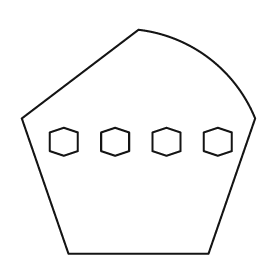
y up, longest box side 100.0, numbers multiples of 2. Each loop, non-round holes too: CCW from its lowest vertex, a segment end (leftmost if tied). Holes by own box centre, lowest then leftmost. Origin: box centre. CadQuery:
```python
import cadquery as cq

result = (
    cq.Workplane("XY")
    .moveTo(-30.0, -48.0)
    .lineTo(30.0, -48.0)
    .lineTo(50.0, 10.0)
    .threePointArc((30.0, 36.0), (0.0, 48.0))
    .lineTo(-50.0, 10.0)
    .close()
    .moveTo(-32.0, -6.0)
    .lineTo(-26.0, -4.0)
    .lineTo(-26.0, 4.0)
    .lineTo(-32.0, 6.0)
    .lineTo(-38.0, 4.0)
    .lineTo(-38.0, -4.0)
    .close()
    .moveTo(-10.0, -6.0)
    .lineTo(-4.0, -4.0)
    .lineTo(-4.0, 4.0)
    .lineTo(-10.0, 6.0)
    .lineTo(-16.0, 4.0)
    .lineTo(-16.0, -4.0)
    .close()
    .moveTo(12.0, -6.0)
    .lineTo(18.0, -4.0)
    .lineTo(18.0, 4.0)
    .lineTo(12.0, 6.0)
    .lineTo(6.0, 4.0)
    .lineTo(6.0, -4.0)
    .close()
    .moveTo(34.0, -6.0)
    .lineTo(40.0, -4.0)
    .lineTo(40.0, 4.0)
    .lineTo(34.0, 6.0)
    .lineTo(28.0, 4.0)
    .lineTo(28.0, -4.0)
    .close()
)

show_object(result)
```